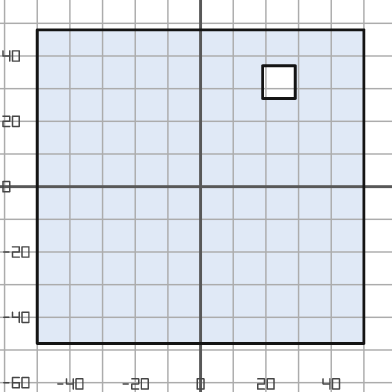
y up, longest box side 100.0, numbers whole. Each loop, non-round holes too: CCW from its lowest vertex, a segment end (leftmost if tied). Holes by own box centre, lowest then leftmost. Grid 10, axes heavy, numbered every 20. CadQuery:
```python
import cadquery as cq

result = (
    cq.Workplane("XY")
    .moveTo(-50.0, -48.0)
    .lineTo(50.0, -48.0)
    .lineTo(50.0, 48.0)
    .lineTo(-50.0, 48.0)
    .close()
    .moveTo(19.0, 27.0)
    .lineTo(29.0, 27.0)
    .lineTo(29.0, 37.0)
    .lineTo(19.0, 37.0)
    .close()
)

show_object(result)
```